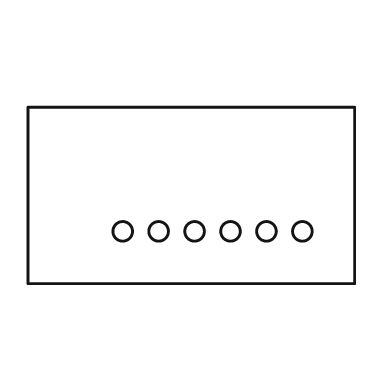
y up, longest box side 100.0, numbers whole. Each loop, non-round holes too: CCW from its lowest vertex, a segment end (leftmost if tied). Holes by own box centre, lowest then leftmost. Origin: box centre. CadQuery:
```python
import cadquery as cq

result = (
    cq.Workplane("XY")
    .moveTo(-50.0, -27.0)
    .lineTo(50.0, -27.0)
    .lineTo(50.0, 27.0)
    .lineTo(-50.0, 27.0)
    .close()
    .moveTo(-21.0, -11.0)
    .circle(3.0)
    .moveTo(-10.0, -11.0)
    .circle(3.0)
    .moveTo(1.0, -11.0)
    .circle(3.0)
    .moveTo(12.0, -11.0)
    .circle(3.0)
    .moveTo(23.0, -11.0)
    .circle(3.0)
    .moveTo(34.0, -11.0)
    .circle(3.0)
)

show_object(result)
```